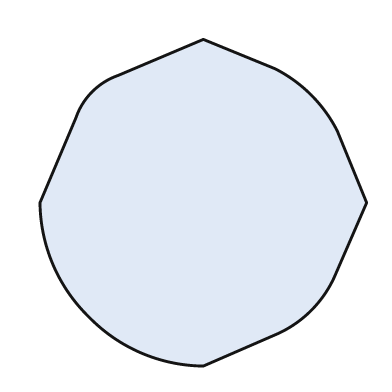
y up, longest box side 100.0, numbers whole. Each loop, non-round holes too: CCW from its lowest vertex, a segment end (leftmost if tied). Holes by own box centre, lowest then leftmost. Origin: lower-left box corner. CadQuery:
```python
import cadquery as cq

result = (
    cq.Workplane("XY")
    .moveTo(50.0, 0.0)
    .lineTo(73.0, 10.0)
    .threePointArc((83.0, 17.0), (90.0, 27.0))
    .lineTo(100.0, 50.0)
    .lineTo(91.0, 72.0)
    .threePointArc((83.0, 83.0), (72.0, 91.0))
    .lineTo(50.0, 100.0)
    .lineTo(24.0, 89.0)
    .threePointArc((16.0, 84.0), (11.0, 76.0))
    .lineTo(0.0, 50.0)
    .threePointArc((4.0, 31.0), (15.0, 15.0))
    .threePointArc((31.0, 4.0), (50.0, 0.0))
    .close()
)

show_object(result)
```